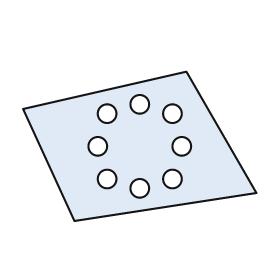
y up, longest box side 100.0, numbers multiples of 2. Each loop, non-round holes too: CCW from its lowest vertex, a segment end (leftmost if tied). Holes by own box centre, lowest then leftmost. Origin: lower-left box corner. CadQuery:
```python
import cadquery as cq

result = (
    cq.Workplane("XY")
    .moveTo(22.0, 0.0)
    .lineTo(100.0, 12.0)
    .lineTo(70.0, 64.0)
    .lineTo(0.0, 48.0)
    .close()
    .moveTo(50.0, 14.0)
    .circle(4.0)
    .moveTo(36.0, 18.0)
    .circle(4.0)
    .moveTo(64.0, 18.0)
    .circle(4.0)
    .moveTo(32.0, 32.0)
    .circle(4.0)
    .moveTo(68.0, 32.0)
    .circle(4.0)
    .moveTo(36.0, 46.0)
    .circle(4.0)
    .moveTo(64.0, 46.0)
    .circle(4.0)
    .moveTo(50.0, 50.0)
    .circle(4.0)
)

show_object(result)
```